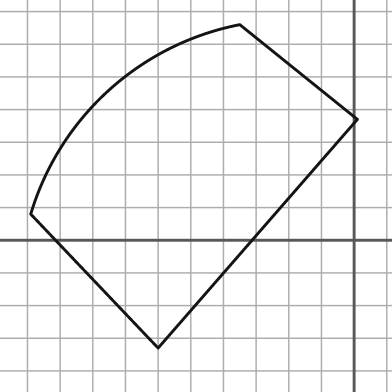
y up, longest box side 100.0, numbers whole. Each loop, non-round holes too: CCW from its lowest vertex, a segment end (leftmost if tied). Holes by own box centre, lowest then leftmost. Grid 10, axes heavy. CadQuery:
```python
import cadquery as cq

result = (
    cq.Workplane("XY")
    .moveTo(-60.0, -33.0)
    .lineTo(1.0, 37.0)
    .lineTo(-35.0, 66.0)
    .threePointArc((-75.0, 46.0), (-99.0, 8.0))
    .close()
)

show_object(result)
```